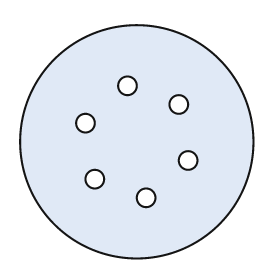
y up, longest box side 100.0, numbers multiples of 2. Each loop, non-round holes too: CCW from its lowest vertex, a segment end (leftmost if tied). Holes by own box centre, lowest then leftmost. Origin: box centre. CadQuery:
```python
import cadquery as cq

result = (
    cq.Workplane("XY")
    .moveTo(0.0, 0.0)
    .circle(50.0)
    .moveTo(4.0, -24.0)
    .circle(4.0)
    .moveTo(-18.0, -16.0)
    .circle(4.0)
    .moveTo(22.0, -8.0)
    .circle(4.0)
    .moveTo(-22.0, 8.0)
    .circle(4.0)
    .moveTo(18.0, 16.0)
    .circle(4.0)
    .moveTo(-4.0, 24.0)
    .circle(4.0)
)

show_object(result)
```